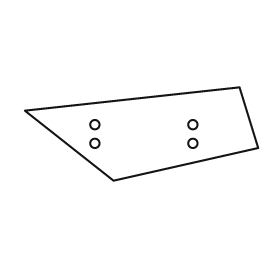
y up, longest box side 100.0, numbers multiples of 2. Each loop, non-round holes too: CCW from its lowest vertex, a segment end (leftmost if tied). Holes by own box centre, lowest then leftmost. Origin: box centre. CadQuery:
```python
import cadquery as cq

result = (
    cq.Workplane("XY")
    .moveTo(-12.0, -20.0)
    .lineTo(50.0, -6.0)
    .lineTo(42.0, 20.0)
    .lineTo(-50.0, 10.0)
    .close()
    .moveTo(-20.0, -4.0)
    .circle(2.0)
    .moveTo(22.0, -4.0)
    .circle(2.0)
    .moveTo(-20.0, 4.0)
    .circle(2.0)
    .moveTo(22.0, 4.0)
    .circle(2.0)
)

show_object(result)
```